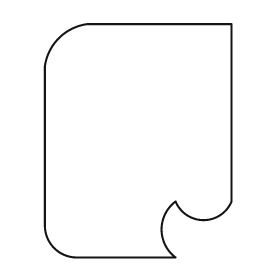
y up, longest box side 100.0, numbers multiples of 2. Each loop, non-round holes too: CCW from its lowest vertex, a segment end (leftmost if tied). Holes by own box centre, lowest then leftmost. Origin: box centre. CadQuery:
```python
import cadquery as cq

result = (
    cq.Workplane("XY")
    .moveTo(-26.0, -50.0)
    .lineTo(16.0, -50.0)
    .threePointArc((10.0, -38.0), (16.0, -26.0))
    .threePointArc((28.0, -34.0), (40.0, -26.0))
    .lineTo(40.0, 50.0)
    .lineTo(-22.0, 50.0)
    .threePointArc((-34.0, 44.0), (-40.0, 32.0))
    .lineTo(-40.0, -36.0)
    .threePointArc((-36.0, -46.0), (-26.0, -50.0))
    .close()
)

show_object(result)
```